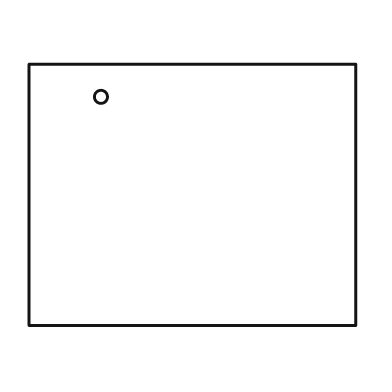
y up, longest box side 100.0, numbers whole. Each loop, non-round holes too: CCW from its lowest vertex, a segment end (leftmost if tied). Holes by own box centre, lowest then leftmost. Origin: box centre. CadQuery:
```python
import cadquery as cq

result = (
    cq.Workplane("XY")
    .moveTo(-50.0, -40.0)
    .lineTo(50.0, -40.0)
    .lineTo(50.0, 40.0)
    .lineTo(-50.0, 40.0)
    .close()
    .moveTo(-28.0, 30.0)
    .circle(2.0)
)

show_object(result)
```